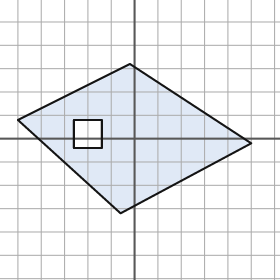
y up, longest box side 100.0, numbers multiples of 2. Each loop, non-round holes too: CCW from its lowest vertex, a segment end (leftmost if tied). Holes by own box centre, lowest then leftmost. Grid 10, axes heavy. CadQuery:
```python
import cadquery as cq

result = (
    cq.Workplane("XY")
    .moveTo(-6.0, -32.0)
    .lineTo(50.0, -2.0)
    .lineTo(-2.0, 32.0)
    .lineTo(-50.0, 8.0)
    .close()
    .moveTo(-26.0, -4.0)
    .lineTo(-14.0, -4.0)
    .lineTo(-14.0, 8.0)
    .lineTo(-26.0, 8.0)
    .close()
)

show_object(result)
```